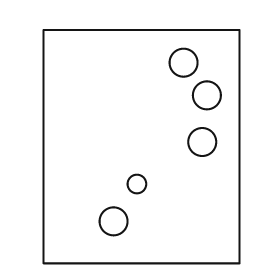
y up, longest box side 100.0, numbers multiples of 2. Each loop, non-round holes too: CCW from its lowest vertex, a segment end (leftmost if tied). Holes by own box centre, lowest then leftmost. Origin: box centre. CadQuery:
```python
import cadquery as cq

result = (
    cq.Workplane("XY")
    .moveTo(-42.0, -50.0)
    .lineTo(42.0, -50.0)
    .lineTo(42.0, 50.0)
    .lineTo(-42.0, 50.0)
    .close()
    .moveTo(-12.0, -32.0)
    .circle(6.0)
    .moveTo(-2.0, -16.0)
    .circle(4.0)
    .moveTo(26.0, 2.0)
    .circle(6.0)
    .moveTo(28.0, 22.0)
    .circle(6.0)
    .moveTo(18.0, 36.0)
    .circle(6.0)
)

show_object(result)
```